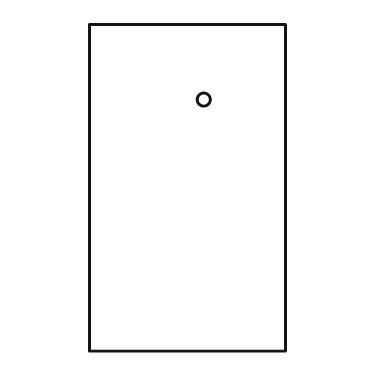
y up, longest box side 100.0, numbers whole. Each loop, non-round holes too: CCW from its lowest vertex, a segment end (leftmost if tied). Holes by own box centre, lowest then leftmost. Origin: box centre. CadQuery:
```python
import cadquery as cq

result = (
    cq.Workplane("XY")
    .moveTo(-30.0, -50.0)
    .lineTo(30.0, -50.0)
    .lineTo(30.0, 50.0)
    .lineTo(-30.0, 50.0)
    .close()
    .moveTo(5.0, 27.0)
    .circle(2.0)
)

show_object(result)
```